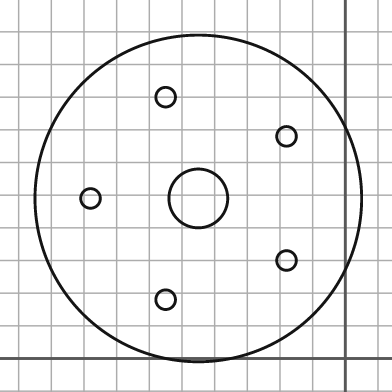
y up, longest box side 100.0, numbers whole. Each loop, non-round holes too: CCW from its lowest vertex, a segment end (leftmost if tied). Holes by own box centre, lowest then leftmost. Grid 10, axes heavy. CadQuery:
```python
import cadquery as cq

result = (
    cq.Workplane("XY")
    .moveTo(-45.0, 49.0)
    .circle(50.0)
    .moveTo(-55.0, 18.0)
    .circle(3.0)
    .moveTo(-18.0, 30.0)
    .circle(3.0)
    .moveTo(-78.0, 49.0)
    .circle(3.0)
    .moveTo(-45.0, 49.0)
    .circle(9.0)
    .moveTo(-18.0, 68.0)
    .circle(3.0)
    .moveTo(-55.0, 80.0)
    .circle(3.0)
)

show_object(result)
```